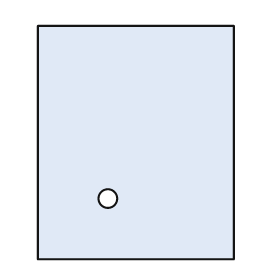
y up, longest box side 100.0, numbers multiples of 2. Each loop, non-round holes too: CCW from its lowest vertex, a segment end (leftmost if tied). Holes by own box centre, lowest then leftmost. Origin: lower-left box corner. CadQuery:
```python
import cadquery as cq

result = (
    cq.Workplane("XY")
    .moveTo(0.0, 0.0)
    .lineTo(84.0, 0.0)
    .lineTo(84.0, 100.0)
    .lineTo(0.0, 100.0)
    .close()
    .moveTo(30.0, 26.0)
    .circle(4.0)
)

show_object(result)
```